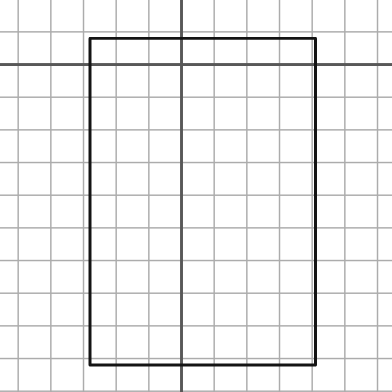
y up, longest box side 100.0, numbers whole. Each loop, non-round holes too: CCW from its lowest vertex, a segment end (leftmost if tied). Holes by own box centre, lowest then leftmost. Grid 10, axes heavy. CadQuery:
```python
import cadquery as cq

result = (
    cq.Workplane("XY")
    .moveTo(-28.0, -92.0)
    .lineTo(41.0, -92.0)
    .lineTo(41.0, 8.0)
    .lineTo(-28.0, 8.0)
    .close()
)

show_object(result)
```